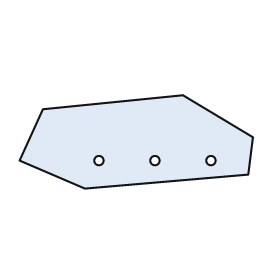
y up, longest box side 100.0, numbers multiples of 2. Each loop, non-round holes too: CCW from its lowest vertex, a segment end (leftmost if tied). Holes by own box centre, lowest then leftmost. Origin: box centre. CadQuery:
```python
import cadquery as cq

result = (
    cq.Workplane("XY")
    .moveTo(-22.0, -20.0)
    .lineTo(48.0, -14.0)
    .lineTo(50.0, 2.0)
    .lineTo(20.0, 20.0)
    .lineTo(-40.0, 14.0)
    .lineTo(-50.0, -8.0)
    .close()
    .moveTo(-16.0, -8.0)
    .circle(2.0)
    .moveTo(8.0, -8.0)
    .circle(2.0)
    .moveTo(32.0, -8.0)
    .circle(2.0)
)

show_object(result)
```